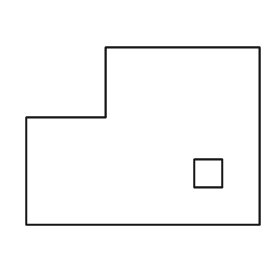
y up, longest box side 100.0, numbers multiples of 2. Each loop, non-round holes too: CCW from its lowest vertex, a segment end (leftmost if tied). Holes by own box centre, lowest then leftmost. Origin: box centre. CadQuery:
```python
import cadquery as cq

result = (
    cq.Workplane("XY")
    .moveTo(-50.0, -38.0)
    .lineTo(50.0, -38.0)
    .lineTo(50.0, 38.0)
    .lineTo(-16.0, 38.0)
    .lineTo(-16.0, 8.0)
    .lineTo(-50.0, 8.0)
    .close()
    .moveTo(22.0, -22.0)
    .lineTo(34.0, -22.0)
    .lineTo(34.0, -10.0)
    .lineTo(22.0, -10.0)
    .close()
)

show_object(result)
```